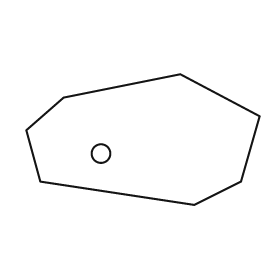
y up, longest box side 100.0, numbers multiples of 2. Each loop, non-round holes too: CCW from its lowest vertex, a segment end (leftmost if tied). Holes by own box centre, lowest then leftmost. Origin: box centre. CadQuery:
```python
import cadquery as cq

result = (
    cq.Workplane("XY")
    .moveTo(22.0, -28.0)
    .lineTo(42.0, -18.0)
    .lineTo(50.0, 10.0)
    .lineTo(16.0, 28.0)
    .lineTo(-34.0, 18.0)
    .lineTo(-50.0, 4.0)
    .lineTo(-44.0, -18.0)
    .close()
    .moveTo(-18.0, -6.0)
    .circle(4.0)
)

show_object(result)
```